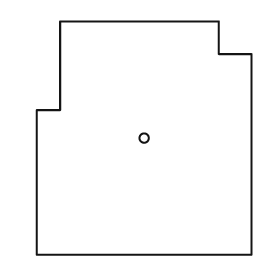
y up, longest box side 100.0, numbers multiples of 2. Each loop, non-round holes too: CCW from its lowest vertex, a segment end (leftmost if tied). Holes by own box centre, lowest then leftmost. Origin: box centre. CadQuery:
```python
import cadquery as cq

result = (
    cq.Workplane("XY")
    .moveTo(-46.0, -50.0)
    .lineTo(46.0, -50.0)
    .lineTo(46.0, 36.0)
    .lineTo(32.0, 36.0)
    .lineTo(32.0, 50.0)
    .lineTo(-36.0, 50.0)
    .lineTo(-36.0, 12.0)
    .lineTo(-46.0, 12.0)
    .close()
    .moveTo(0.0, 0.0)
    .circle(2.0)
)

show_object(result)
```